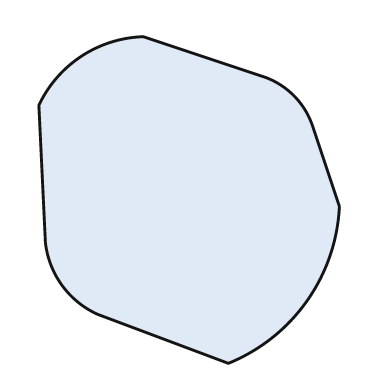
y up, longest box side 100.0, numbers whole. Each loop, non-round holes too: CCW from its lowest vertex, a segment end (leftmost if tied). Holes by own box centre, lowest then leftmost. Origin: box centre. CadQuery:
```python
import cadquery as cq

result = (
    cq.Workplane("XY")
    .moveTo(12.0, -50.0)
    .threePointArc((36.0, -31.0), (46.0, -2.0))
    .lineTo(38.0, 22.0)
    .threePointArc((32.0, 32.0), (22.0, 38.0))
    .lineTo(-14.0, 50.0)
    .threePointArc((-33.0, 44.0), (-46.0, 29.0))
    .lineTo(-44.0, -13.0)
    .threePointArc((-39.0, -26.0), (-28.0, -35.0))
    .close()
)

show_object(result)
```